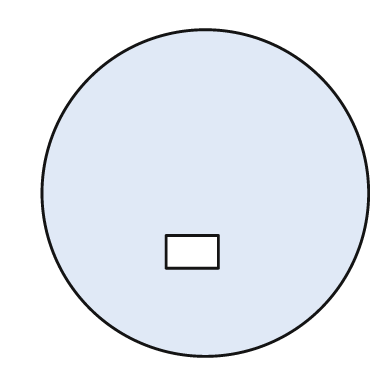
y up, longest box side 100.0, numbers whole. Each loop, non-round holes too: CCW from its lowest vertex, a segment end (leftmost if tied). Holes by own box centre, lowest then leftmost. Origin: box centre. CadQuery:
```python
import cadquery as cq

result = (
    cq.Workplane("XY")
    .moveTo(0.0, 0.0)
    .circle(50.0)
    .moveTo(-12.0, -23.0)
    .lineTo(4.0, -23.0)
    .lineTo(4.0, -13.0)
    .lineTo(-12.0, -13.0)
    .close()
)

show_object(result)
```